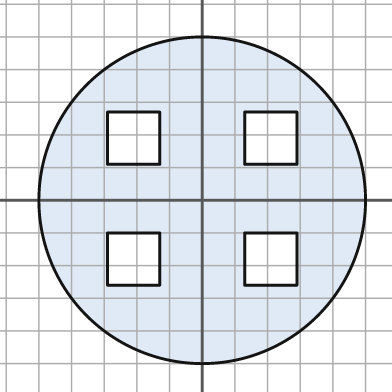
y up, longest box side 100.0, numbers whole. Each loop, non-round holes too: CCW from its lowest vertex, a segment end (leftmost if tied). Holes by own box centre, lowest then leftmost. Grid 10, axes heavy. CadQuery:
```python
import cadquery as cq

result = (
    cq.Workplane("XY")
    .moveTo(0.0, 0.0)
    .circle(50.0)
    .moveTo(-29.0, -26.0)
    .lineTo(-13.0, -26.0)
    .lineTo(-13.0, -10.0)
    .lineTo(-29.0, -10.0)
    .close()
    .moveTo(13.0, -26.0)
    .lineTo(29.0, -26.0)
    .lineTo(29.0, -10.0)
    .lineTo(13.0, -10.0)
    .close()
    .moveTo(-29.0, 11.0)
    .lineTo(-13.0, 11.0)
    .lineTo(-13.0, 27.0)
    .lineTo(-29.0, 27.0)
    .close()
    .moveTo(13.0, 11.0)
    .lineTo(29.0, 11.0)
    .lineTo(29.0, 27.0)
    .lineTo(13.0, 27.0)
    .close()
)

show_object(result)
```